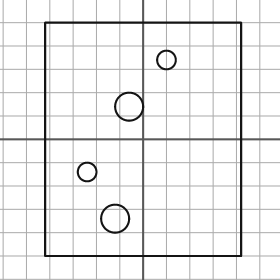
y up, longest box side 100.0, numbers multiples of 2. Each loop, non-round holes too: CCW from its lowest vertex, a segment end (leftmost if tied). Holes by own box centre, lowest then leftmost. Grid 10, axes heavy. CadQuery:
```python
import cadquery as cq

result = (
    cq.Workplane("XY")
    .moveTo(-42.0, -50.0)
    .lineTo(42.0, -50.0)
    .lineTo(42.0, 50.0)
    .lineTo(-42.0, 50.0)
    .close()
    .moveTo(-12.0, -34.0)
    .circle(6.0)
    .moveTo(-24.0, -14.0)
    .circle(4.0)
    .moveTo(-6.0, 14.0)
    .circle(6.0)
    .moveTo(10.0, 34.0)
    .circle(4.0)
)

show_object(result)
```